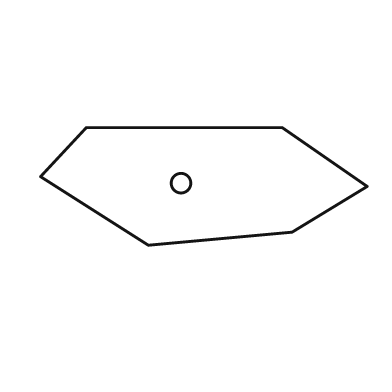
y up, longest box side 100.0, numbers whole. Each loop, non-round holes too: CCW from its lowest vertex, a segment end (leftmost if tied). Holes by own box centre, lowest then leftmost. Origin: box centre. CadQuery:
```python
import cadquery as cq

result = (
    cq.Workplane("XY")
    .moveTo(-17.0, -18.0)
    .lineTo(27.0, -14.0)
    .lineTo(50.0, 0.0)
    .lineTo(24.0, 18.0)
    .lineTo(-36.0, 18.0)
    .lineTo(-50.0, 3.0)
    .close()
    .moveTo(-7.0, 1.0)
    .circle(3.0)
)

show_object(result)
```